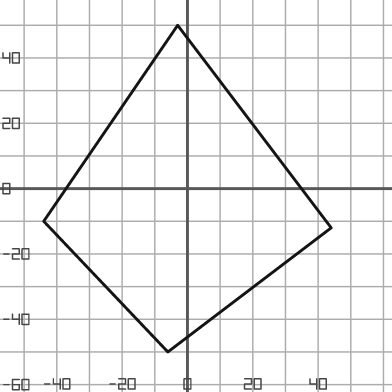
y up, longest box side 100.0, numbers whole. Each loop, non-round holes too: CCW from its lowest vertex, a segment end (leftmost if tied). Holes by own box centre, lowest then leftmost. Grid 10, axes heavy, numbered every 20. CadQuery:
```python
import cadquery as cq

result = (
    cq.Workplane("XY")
    .moveTo(-6.0, -50.0)
    .lineTo(44.0, -12.0)
    .lineTo(-3.0, 50.0)
    .lineTo(-44.0, -10.0)
    .close()
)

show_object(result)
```